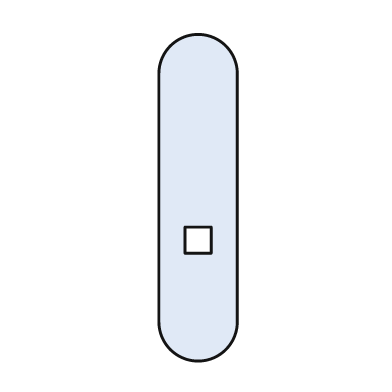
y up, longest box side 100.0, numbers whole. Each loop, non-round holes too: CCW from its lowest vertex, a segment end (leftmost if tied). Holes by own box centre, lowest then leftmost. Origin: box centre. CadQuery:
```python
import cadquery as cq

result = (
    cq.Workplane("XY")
    .moveTo(-12.0, -38.0)
    .threePointArc((0.0, -50.0), (12.0, -38.0))
    .lineTo(12.0, 38.0)
    .threePointArc((0.0, 50.0), (-12.0, 38.0))
    .close()
    .moveTo(-4.0, -17.0)
    .lineTo(4.0, -17.0)
    .lineTo(4.0, -9.0)
    .lineTo(-4.0, -9.0)
    .close()
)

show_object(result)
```